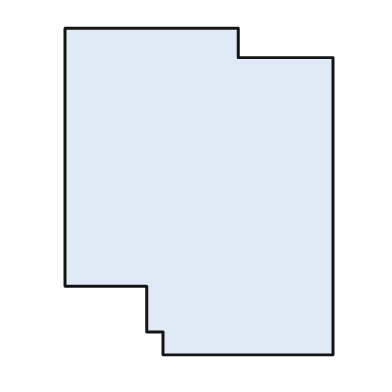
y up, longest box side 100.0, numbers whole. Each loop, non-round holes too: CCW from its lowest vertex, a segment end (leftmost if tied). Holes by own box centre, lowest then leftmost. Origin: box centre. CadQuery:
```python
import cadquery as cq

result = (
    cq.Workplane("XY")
    .moveTo(-11.0, -50.0)
    .lineTo(41.0, -50.0)
    .lineTo(41.0, 41.0)
    .lineTo(12.0, 41.0)
    .lineTo(12.0, 50.0)
    .lineTo(-41.0, 50.0)
    .lineTo(-41.0, -29.0)
    .lineTo(-16.0, -29.0)
    .lineTo(-16.0, -43.0)
    .lineTo(-11.0, -43.0)
    .close()
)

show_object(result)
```